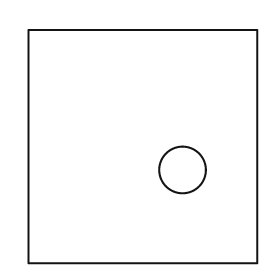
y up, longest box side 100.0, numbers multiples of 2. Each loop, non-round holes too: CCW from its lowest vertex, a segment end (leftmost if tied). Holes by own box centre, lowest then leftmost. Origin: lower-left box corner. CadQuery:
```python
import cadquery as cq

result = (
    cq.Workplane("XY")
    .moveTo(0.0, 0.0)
    .lineTo(98.0, 0.0)
    .lineTo(98.0, 100.0)
    .lineTo(0.0, 100.0)
    .close()
    .moveTo(66.0, 40.0)
    .circle(10.0)
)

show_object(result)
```